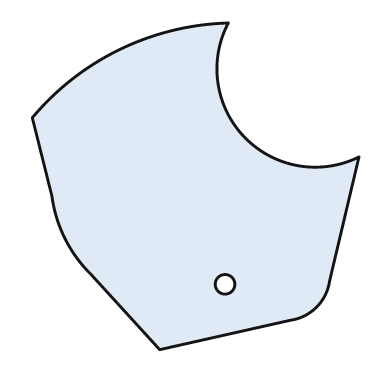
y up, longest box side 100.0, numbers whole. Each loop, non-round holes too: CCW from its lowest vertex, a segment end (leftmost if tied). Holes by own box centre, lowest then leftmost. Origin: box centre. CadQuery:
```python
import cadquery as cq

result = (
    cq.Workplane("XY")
    .moveTo(-11.0, -50.0)
    .lineTo(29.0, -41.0)
    .threePointArc((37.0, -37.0), (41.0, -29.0))
    .lineTo(50.0, 9.0)
    .threePointArc((15.0, 15.0), (10.0, 50.0))
    .threePointArc((-23.0, 42.0), (-50.0, 21.0))
    .lineTo(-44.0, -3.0)
    .threePointArc((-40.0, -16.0), (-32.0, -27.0))
    .close()
    .moveTo(9.0, -30.0)
    .circle(3.0)
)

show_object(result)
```